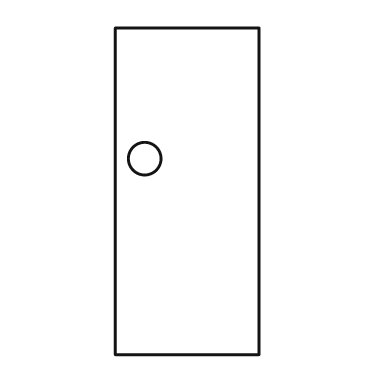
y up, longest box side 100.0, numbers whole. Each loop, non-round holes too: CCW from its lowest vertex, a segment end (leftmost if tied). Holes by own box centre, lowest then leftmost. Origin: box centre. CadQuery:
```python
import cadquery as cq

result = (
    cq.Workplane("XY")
    .moveTo(-22.0, -50.0)
    .lineTo(22.0, -50.0)
    .lineTo(22.0, 50.0)
    .lineTo(-22.0, 50.0)
    .close()
    .moveTo(-13.0, 10.0)
    .circle(5.0)
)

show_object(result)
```